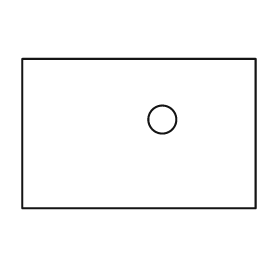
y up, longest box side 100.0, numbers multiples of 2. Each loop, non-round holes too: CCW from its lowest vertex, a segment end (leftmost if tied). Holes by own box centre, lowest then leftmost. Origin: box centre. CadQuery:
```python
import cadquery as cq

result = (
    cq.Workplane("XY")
    .moveTo(-50.0, -32.0)
    .lineTo(50.0, -32.0)
    .lineTo(50.0, 32.0)
    .lineTo(-50.0, 32.0)
    .close()
    .moveTo(10.0, 6.0)
    .circle(6.0)
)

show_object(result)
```